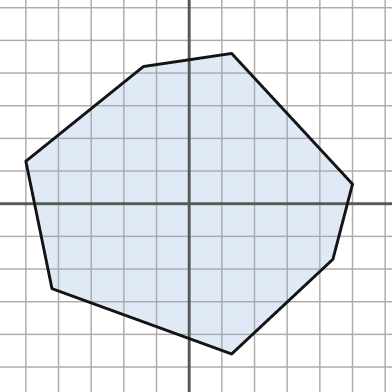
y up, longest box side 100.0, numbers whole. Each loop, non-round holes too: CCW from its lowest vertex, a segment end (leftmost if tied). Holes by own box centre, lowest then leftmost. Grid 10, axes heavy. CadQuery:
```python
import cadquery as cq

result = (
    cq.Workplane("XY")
    .moveTo(13.0, -46.0)
    .lineTo(44.0, -17.0)
    .lineTo(50.0, 6.0)
    .lineTo(13.0, 46.0)
    .lineTo(-14.0, 42.0)
    .lineTo(-50.0, 13.0)
    .lineTo(-42.0, -26.0)
    .close()
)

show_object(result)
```